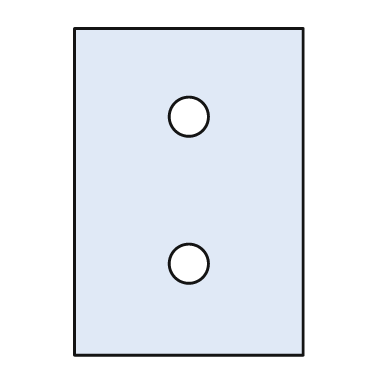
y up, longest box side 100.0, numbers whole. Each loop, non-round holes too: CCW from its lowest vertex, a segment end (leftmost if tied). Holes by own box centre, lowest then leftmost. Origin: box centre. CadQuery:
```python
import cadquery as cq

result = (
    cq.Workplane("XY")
    .moveTo(-35.0, -50.0)
    .lineTo(35.0, -50.0)
    .lineTo(35.0, 50.0)
    .lineTo(-35.0, 50.0)
    .close()
    .moveTo(0.0, -22.0)
    .circle(6.0)
    .moveTo(0.0, 23.0)
    .circle(6.0)
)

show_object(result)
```